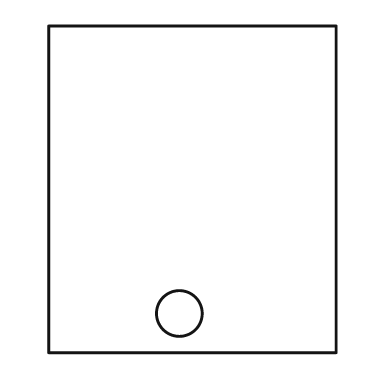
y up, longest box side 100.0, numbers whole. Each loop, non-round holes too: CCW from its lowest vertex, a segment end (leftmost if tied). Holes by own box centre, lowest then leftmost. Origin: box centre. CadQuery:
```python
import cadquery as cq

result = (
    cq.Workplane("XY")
    .moveTo(-44.0, -50.0)
    .lineTo(44.0, -50.0)
    .lineTo(44.0, 50.0)
    .lineTo(-44.0, 50.0)
    .close()
    .moveTo(-4.0, -38.0)
    .circle(7.0)
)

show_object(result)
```